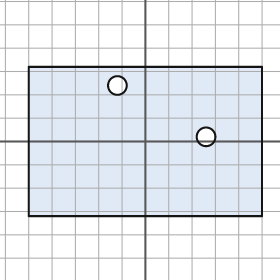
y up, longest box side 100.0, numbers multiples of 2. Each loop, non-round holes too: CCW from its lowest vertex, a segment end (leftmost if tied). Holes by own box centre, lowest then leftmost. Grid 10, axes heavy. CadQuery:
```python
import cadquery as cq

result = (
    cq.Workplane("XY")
    .moveTo(-50.0, -32.0)
    .lineTo(50.0, -32.0)
    .lineTo(50.0, 32.0)
    .lineTo(-50.0, 32.0)
    .close()
    .moveTo(26.0, 2.0)
    .circle(4.0)
    .moveTo(-12.0, 24.0)
    .circle(4.0)
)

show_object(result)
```